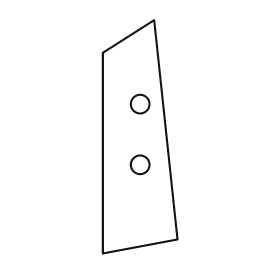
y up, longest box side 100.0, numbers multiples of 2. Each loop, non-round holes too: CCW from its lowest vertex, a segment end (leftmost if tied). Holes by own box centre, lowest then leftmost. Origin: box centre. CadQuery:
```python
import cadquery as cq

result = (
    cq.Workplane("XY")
    .moveTo(-16.0, -50.0)
    .lineTo(16.0, -44.0)
    .lineTo(6.0, 50.0)
    .lineTo(-16.0, 36.0)
    .close()
    .moveTo(0.0, -12.0)
    .circle(4.0)
    .moveTo(0.0, 14.0)
    .circle(4.0)
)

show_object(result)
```